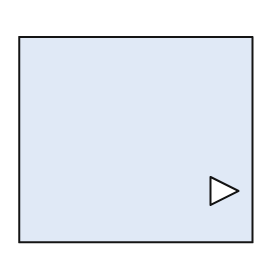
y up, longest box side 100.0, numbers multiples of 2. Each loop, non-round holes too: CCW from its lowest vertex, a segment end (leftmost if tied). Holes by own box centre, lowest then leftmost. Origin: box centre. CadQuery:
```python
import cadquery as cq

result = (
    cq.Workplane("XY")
    .moveTo(-50.0, -44.0)
    .lineTo(50.0, -44.0)
    .lineTo(50.0, 44.0)
    .lineTo(-50.0, 44.0)
    .close()
    .moveTo(32.0, -28.0)
    .lineTo(44.0, -22.0)
    .lineTo(32.0, -16.0)
    .close()
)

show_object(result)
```